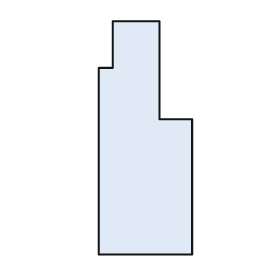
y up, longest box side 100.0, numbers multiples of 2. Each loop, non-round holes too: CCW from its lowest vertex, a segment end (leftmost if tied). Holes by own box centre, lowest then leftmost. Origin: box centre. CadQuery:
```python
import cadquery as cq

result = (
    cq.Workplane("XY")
    .moveTo(-20.0, -50.0)
    .lineTo(20.0, -50.0)
    .lineTo(20.0, 8.0)
    .lineTo(6.0, 8.0)
    .lineTo(6.0, 50.0)
    .lineTo(-14.0, 50.0)
    .lineTo(-14.0, 30.0)
    .lineTo(-20.0, 30.0)
    .close()
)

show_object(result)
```